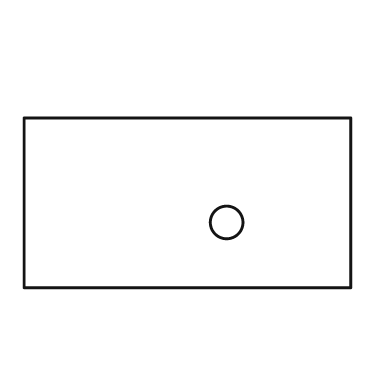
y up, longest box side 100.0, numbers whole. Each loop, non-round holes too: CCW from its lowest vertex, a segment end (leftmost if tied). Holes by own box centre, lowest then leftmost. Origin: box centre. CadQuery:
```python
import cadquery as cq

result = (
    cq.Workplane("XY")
    .moveTo(-50.0, -26.0)
    .lineTo(50.0, -26.0)
    .lineTo(50.0, 26.0)
    .lineTo(-50.0, 26.0)
    .close()
    .moveTo(12.0, -6.0)
    .circle(5.0)
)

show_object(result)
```